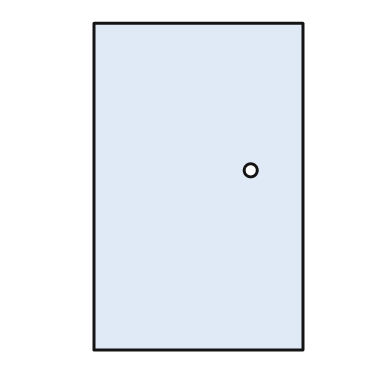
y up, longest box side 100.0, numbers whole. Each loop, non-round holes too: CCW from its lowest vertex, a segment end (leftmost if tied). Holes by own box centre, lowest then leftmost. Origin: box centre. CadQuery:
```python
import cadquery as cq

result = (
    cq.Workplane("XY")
    .moveTo(-32.0, -50.0)
    .lineTo(32.0, -50.0)
    .lineTo(32.0, 50.0)
    .lineTo(-32.0, 50.0)
    .close()
    .moveTo(16.0, 5.0)
    .circle(2.0)
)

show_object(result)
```